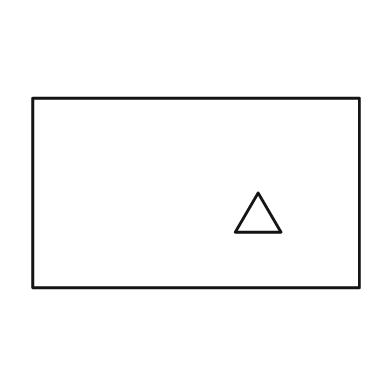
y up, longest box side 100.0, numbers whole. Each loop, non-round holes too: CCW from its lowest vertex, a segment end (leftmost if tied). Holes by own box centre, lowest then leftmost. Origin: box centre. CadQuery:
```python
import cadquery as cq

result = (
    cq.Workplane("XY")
    .moveTo(-50.0, -29.0)
    .lineTo(50.0, -29.0)
    .lineTo(50.0, 29.0)
    .lineTo(-50.0, 29.0)
    .close()
    .moveTo(12.0, -12.0)
    .lineTo(26.0, -12.0)
    .lineTo(19.0, 0.0)
    .close()
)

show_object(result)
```